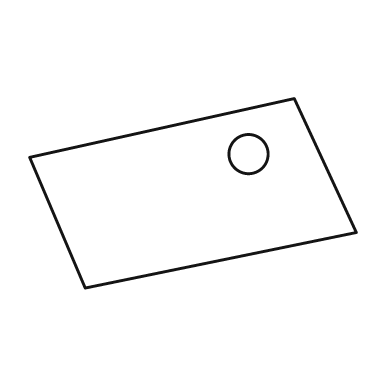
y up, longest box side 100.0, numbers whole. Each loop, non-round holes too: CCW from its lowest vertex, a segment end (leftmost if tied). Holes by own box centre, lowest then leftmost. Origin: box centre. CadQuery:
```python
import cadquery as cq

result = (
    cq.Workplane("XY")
    .moveTo(-33.0, -29.0)
    .lineTo(50.0, -12.0)
    .lineTo(31.0, 29.0)
    .lineTo(-50.0, 11.0)
    .close()
    .moveTo(17.0, 12.0)
    .circle(6.0)
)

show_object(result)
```